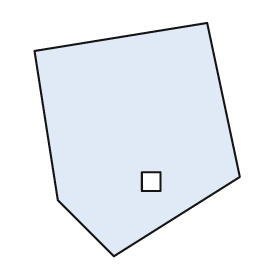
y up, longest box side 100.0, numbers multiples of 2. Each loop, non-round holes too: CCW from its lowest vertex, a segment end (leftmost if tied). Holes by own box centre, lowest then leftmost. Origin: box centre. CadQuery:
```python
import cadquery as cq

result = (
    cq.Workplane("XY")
    .moveTo(-10.0, -50.0)
    .lineTo(44.0, -16.0)
    .lineTo(30.0, 50.0)
    .lineTo(-44.0, 38.0)
    .lineTo(-34.0, -26.0)
    .close()
    .moveTo(2.0, -22.0)
    .lineTo(10.0, -22.0)
    .lineTo(10.0, -14.0)
    .lineTo(2.0, -14.0)
    .close()
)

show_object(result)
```